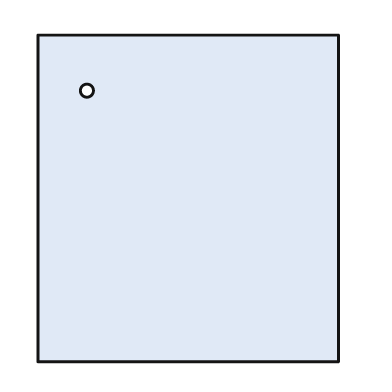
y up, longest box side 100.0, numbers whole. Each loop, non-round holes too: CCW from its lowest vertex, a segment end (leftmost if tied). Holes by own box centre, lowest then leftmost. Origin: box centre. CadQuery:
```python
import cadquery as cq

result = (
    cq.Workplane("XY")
    .moveTo(-46.0, -50.0)
    .lineTo(46.0, -50.0)
    .lineTo(46.0, 50.0)
    .lineTo(-46.0, 50.0)
    .close()
    .moveTo(-31.0, 33.0)
    .circle(2.0)
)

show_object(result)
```